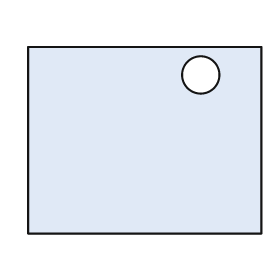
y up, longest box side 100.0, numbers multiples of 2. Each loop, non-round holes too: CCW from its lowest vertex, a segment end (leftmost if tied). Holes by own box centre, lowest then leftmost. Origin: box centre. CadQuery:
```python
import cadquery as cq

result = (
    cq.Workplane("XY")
    .moveTo(-50.0, -40.0)
    .lineTo(50.0, -40.0)
    .lineTo(50.0, 40.0)
    .lineTo(-50.0, 40.0)
    .close()
    .moveTo(24.0, 28.0)
    .circle(8.0)
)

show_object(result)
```